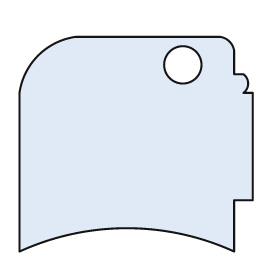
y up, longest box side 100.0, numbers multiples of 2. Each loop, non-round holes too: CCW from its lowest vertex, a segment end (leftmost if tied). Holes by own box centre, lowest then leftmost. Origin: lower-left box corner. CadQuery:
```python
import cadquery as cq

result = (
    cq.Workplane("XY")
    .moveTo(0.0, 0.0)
    .threePointArc((46.0, 10.0), (92.0, 0.0))
    .lineTo(92.0, 22.0)
    .lineTo(100.0, 22.0)
    .lineTo(100.0, 68.0)
    .lineTo(96.0, 68.0)
    .threePointArc((98.0, 72.0), (96.0, 76.0))
    .lineTo(92.0, 76.0)
    .lineTo(92.0, 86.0)
    .threePointArc((90.0, 90.0), (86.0, 92.0))
    .lineTo(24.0, 92.0)
    .threePointArc((8.0, 84.0), (0.0, 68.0))
    .close()
    .moveTo(70.0, 80.0)
    .circle(8.0)
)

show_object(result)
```